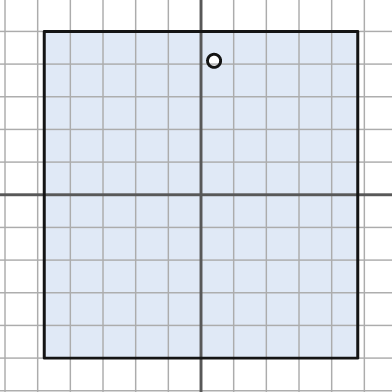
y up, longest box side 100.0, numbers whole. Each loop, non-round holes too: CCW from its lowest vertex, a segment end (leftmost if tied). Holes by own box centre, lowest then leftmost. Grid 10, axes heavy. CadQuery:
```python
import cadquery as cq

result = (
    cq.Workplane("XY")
    .moveTo(-48.0, -50.0)
    .lineTo(48.0, -50.0)
    .lineTo(48.0, 50.0)
    .lineTo(-48.0, 50.0)
    .close()
    .moveTo(4.0, 41.0)
    .circle(2.0)
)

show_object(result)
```